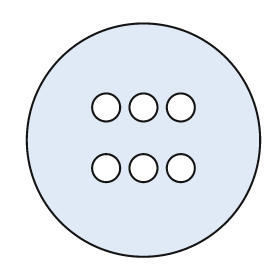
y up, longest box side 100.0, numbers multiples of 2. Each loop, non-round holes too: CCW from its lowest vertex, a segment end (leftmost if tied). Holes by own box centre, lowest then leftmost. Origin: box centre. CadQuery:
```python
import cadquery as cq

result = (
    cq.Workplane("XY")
    .moveTo(0.0, 0.0)
    .circle(50.0)
    .moveTo(-16.0, -12.0)
    .circle(6.0)
    .moveTo(0.0, -12.0)
    .circle(6.0)
    .moveTo(16.0, -12.0)
    .circle(6.0)
    .moveTo(-16.0, 14.0)
    .circle(6.0)
    .moveTo(0.0, 14.0)
    .circle(6.0)
    .moveTo(16.0, 14.0)
    .circle(6.0)
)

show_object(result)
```